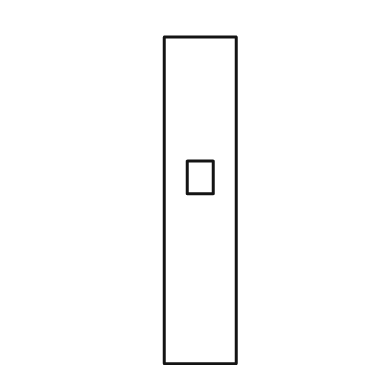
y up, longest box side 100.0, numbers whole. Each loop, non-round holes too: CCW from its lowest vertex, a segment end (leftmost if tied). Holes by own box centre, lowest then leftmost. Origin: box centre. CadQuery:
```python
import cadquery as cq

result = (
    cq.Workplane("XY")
    .moveTo(-11.0, -50.0)
    .lineTo(11.0, -50.0)
    .lineTo(11.0, 50.0)
    .lineTo(-11.0, 50.0)
    .close()
    .moveTo(-4.0, 2.0)
    .lineTo(4.0, 2.0)
    .lineTo(4.0, 12.0)
    .lineTo(-4.0, 12.0)
    .close()
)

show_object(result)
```